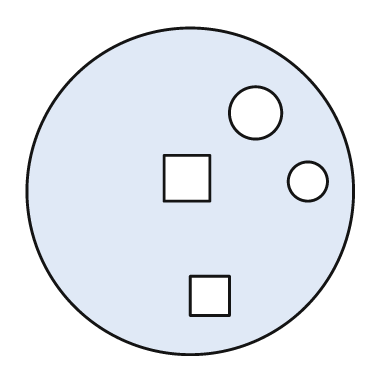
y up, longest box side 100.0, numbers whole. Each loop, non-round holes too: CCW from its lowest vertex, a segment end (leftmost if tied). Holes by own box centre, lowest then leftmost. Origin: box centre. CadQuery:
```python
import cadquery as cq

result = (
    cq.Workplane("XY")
    .moveTo(0.0, 0.0)
    .circle(50.0)
    .moveTo(0.0, -38.0)
    .lineTo(12.0, -38.0)
    .lineTo(12.0, -26.0)
    .lineTo(0.0, -26.0)
    .close()
    .moveTo(36.0, 3.0)
    .circle(6.0)
    .moveTo(-8.0, -3.0)
    .lineTo(6.0, -3.0)
    .lineTo(6.0, 11.0)
    .lineTo(-8.0, 11.0)
    .close()
    .moveTo(20.0, 24.0)
    .circle(8.0)
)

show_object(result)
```